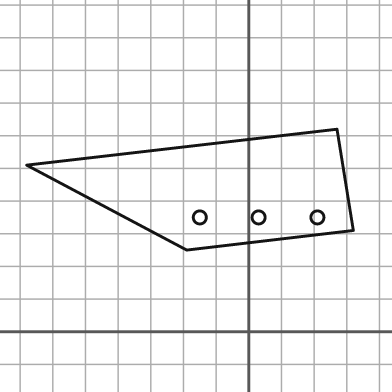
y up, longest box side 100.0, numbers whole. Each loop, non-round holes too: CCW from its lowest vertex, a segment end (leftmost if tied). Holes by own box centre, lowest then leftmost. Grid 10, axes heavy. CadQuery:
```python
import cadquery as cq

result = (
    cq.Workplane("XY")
    .moveTo(-19.0, 25.0)
    .lineTo(32.0, 31.0)
    .lineTo(27.0, 62.0)
    .lineTo(-68.0, 51.0)
    .close()
    .moveTo(-15.0, 35.0)
    .circle(2.0)
    .moveTo(3.0, 35.0)
    .circle(2.0)
    .moveTo(21.0, 35.0)
    .circle(2.0)
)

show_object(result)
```